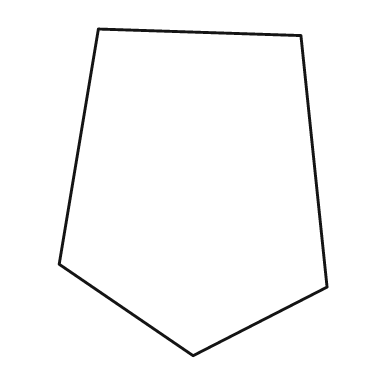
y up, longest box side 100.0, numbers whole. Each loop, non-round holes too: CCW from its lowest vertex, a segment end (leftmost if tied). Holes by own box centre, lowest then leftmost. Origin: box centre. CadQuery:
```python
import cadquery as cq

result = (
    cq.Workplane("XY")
    .moveTo(0.0, -50.0)
    .lineTo(41.0, -29.0)
    .lineTo(33.0, 48.0)
    .lineTo(-29.0, 50.0)
    .lineTo(-41.0, -22.0)
    .close()
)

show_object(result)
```